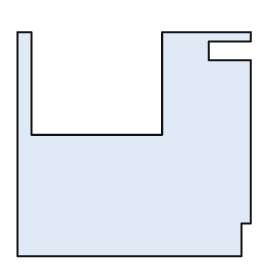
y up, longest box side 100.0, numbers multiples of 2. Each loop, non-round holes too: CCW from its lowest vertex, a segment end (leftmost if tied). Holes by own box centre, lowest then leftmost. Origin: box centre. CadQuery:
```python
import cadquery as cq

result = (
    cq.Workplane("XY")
    .moveTo(-50.0, -48.0)
    .lineTo(46.0, -48.0)
    .lineTo(46.0, -34.0)
    .lineTo(50.0, -34.0)
    .lineTo(50.0, 36.0)
    .lineTo(32.0, 36.0)
    .lineTo(32.0, 44.0)
    .lineTo(50.0, 44.0)
    .lineTo(50.0, 48.0)
    .lineTo(12.0, 48.0)
    .lineTo(12.0, 4.0)
    .lineTo(-44.0, 4.0)
    .lineTo(-44.0, 48.0)
    .lineTo(-50.0, 48.0)
    .close()
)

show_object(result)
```